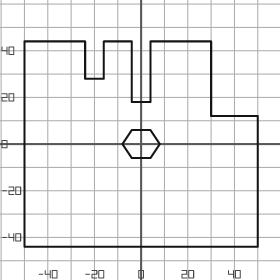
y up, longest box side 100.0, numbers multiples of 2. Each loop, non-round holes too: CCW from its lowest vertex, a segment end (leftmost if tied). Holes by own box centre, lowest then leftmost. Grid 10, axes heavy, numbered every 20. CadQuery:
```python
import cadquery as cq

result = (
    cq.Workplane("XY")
    .moveTo(-50.0, -44.0)
    .lineTo(50.0, -44.0)
    .lineTo(50.0, 12.0)
    .lineTo(30.0, 12.0)
    .lineTo(30.0, 44.0)
    .lineTo(4.0, 44.0)
    .lineTo(4.0, 18.0)
    .lineTo(-4.0, 18.0)
    .lineTo(-4.0, 44.0)
    .lineTo(-16.0, 44.0)
    .lineTo(-16.0, 28.0)
    .lineTo(-24.0, 28.0)
    .lineTo(-24.0, 44.0)
    .lineTo(-50.0, 44.0)
    .close()
    .moveTo(-4.0, -6.0)
    .lineTo(4.0, -6.0)
    .lineTo(8.0, 0.0)
    .lineTo(4.0, 6.0)
    .lineTo(-4.0, 6.0)
    .lineTo(-8.0, 0.0)
    .close()
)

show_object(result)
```